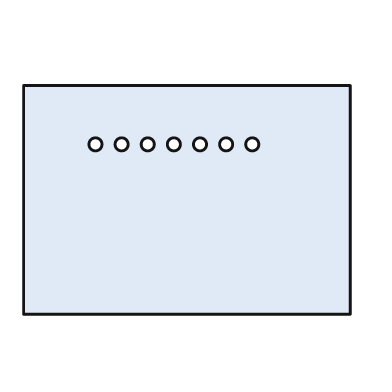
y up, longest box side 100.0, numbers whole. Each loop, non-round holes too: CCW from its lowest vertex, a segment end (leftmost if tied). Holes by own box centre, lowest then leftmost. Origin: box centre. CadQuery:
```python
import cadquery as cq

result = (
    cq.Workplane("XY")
    .moveTo(-50.0, -35.0)
    .lineTo(50.0, -35.0)
    .lineTo(50.0, 35.0)
    .lineTo(-50.0, 35.0)
    .close()
    .moveTo(-28.0, 17.0)
    .circle(2.0)
    .moveTo(-20.0, 17.0)
    .circle(2.0)
    .moveTo(-12.0, 17.0)
    .circle(2.0)
    .moveTo(-4.0, 17.0)
    .circle(2.0)
    .moveTo(4.0, 17.0)
    .circle(2.0)
    .moveTo(12.0, 17.0)
    .circle(2.0)
    .moveTo(20.0, 17.0)
    .circle(2.0)
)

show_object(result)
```